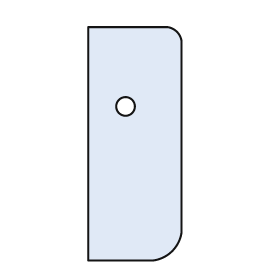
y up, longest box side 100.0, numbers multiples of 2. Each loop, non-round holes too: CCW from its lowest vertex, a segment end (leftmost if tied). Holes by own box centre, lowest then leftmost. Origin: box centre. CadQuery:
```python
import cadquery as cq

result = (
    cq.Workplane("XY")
    .moveTo(-20.0, -50.0)
    .lineTo(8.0, -50.0)
    .threePointArc((16.0, -46.0), (20.0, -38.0))
    .lineTo(20.0, 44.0)
    .threePointArc((18.0, 48.0), (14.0, 50.0))
    .lineTo(-20.0, 50.0)
    .close()
    .moveTo(-4.0, 16.0)
    .circle(4.0)
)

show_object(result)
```